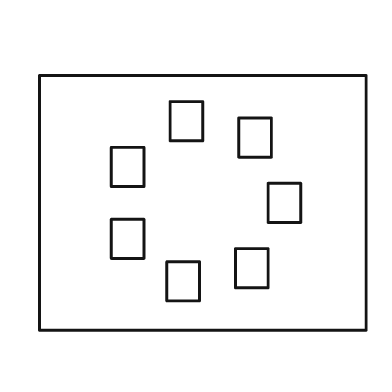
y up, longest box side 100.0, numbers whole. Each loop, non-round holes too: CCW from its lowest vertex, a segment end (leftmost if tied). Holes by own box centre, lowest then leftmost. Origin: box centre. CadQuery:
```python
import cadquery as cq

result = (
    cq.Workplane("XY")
    .moveTo(-50.0, -39.0)
    .lineTo(50.0, -39.0)
    .lineTo(50.0, 39.0)
    .lineTo(-50.0, 39.0)
    .close()
    .moveTo(-11.0, -30.0)
    .lineTo(-1.0, -30.0)
    .lineTo(-1.0, -18.0)
    .lineTo(-11.0, -18.0)
    .close()
    .moveTo(10.0, -26.0)
    .lineTo(20.0, -26.0)
    .lineTo(20.0, -14.0)
    .lineTo(10.0, -14.0)
    .close()
    .moveTo(-28.0, -17.0)
    .lineTo(-18.0, -17.0)
    .lineTo(-18.0, -5.0)
    .lineTo(-28.0, -5.0)
    .close()
    .moveTo(20.0, -6.0)
    .lineTo(30.0, -6.0)
    .lineTo(30.0, 6.0)
    .lineTo(20.0, 6.0)
    .close()
    .moveTo(-28.0, 5.0)
    .lineTo(-18.0, 5.0)
    .lineTo(-18.0, 17.0)
    .lineTo(-28.0, 17.0)
    .close()
    .moveTo(11.0, 14.0)
    .lineTo(21.0, 14.0)
    .lineTo(21.0, 26.0)
    .lineTo(11.0, 26.0)
    .close()
    .moveTo(-10.0, 19.0)
    .lineTo(0.0, 19.0)
    .lineTo(0.0, 31.0)
    .lineTo(-10.0, 31.0)
    .close()
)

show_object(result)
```